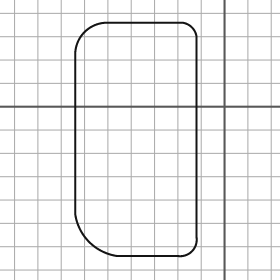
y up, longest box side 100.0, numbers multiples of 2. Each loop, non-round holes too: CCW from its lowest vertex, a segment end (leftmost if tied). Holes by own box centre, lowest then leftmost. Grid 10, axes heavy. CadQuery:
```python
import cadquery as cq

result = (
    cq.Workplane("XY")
    .moveTo(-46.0, -64.0)
    .lineTo(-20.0, -64.0)
    .threePointArc((-14.0, -62.0), (-12.0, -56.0))
    .lineTo(-12.0, 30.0)
    .threePointArc((-14.0, 34.0), (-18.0, 36.0))
    .lineTo(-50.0, 36.0)
    .threePointArc((-60.0, 32.0), (-64.0, 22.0))
    .lineTo(-64.0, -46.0)
    .threePointArc((-58.0, -58.0), (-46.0, -64.0))
    .close()
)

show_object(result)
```